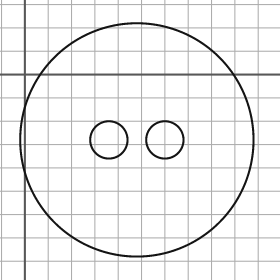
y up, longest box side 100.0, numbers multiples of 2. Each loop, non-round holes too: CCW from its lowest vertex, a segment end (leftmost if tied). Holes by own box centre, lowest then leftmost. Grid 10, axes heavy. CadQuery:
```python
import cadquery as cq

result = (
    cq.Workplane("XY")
    .moveTo(48.0, -28.0)
    .circle(50.0)
    .moveTo(36.0, -28.0)
    .circle(8.0)
    .moveTo(60.0, -28.0)
    .circle(8.0)
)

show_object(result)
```